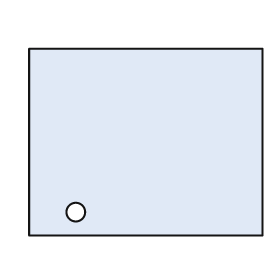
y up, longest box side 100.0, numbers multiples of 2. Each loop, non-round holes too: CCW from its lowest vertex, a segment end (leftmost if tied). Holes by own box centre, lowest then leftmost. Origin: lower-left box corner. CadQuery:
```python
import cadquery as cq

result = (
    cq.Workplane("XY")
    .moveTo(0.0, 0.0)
    .lineTo(100.0, 0.0)
    .lineTo(100.0, 80.0)
    .lineTo(0.0, 80.0)
    .close()
    .moveTo(20.0, 10.0)
    .circle(4.0)
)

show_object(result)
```